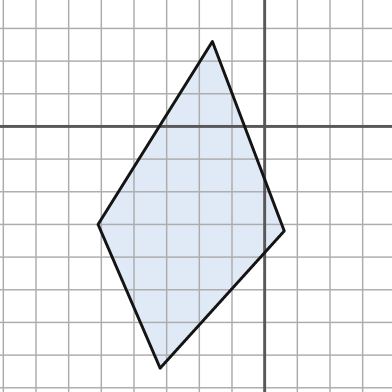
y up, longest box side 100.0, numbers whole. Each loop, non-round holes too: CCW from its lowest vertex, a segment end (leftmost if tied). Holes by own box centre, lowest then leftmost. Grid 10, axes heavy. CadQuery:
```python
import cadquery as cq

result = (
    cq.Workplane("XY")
    .moveTo(-32.0, -74.0)
    .lineTo(6.0, -32.0)
    .lineTo(-16.0, 26.0)
    .lineTo(-51.0, -30.0)
    .close()
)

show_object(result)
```